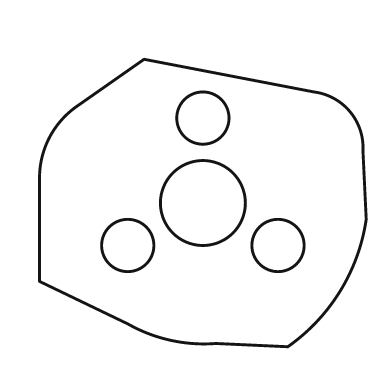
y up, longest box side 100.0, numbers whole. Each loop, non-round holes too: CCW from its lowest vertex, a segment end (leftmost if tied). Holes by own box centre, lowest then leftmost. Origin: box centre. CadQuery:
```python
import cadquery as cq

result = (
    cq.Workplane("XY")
    .moveTo(26.0, -44.0)
    .threePointArc((42.0, -27.0), (50.0, -5.0))
    .lineTo(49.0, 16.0)
    .threePointArc((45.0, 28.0), (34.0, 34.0))
    .lineTo(-18.0, 44.0)
    .lineTo(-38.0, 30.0)
    .threePointArc((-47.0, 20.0), (-50.0, 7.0))
    .lineTo(-50.0, -24.0)
    .lineTo(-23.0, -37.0)
    .threePointArc((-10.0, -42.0), (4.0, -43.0))
    .close()
    .moveTo(-23.0, -13.0)
    .circle(8.0)
    .moveTo(23.0, -13.0)
    .circle(8.0)
    .moveTo(0.0, 0.0)
    .circle(13.0)
    .moveTo(0.0, 26.0)
    .circle(8.0)
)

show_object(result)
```